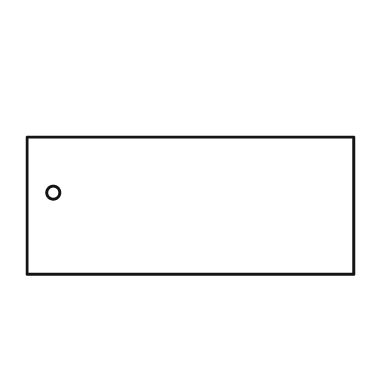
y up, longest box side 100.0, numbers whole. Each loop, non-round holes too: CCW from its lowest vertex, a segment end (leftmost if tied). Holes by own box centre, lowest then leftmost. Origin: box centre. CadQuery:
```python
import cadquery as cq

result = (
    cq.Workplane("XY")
    .moveTo(-50.0, -21.0)
    .lineTo(50.0, -21.0)
    .lineTo(50.0, 21.0)
    .lineTo(-50.0, 21.0)
    .close()
    .moveTo(-42.0, 4.0)
    .circle(2.0)
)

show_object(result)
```